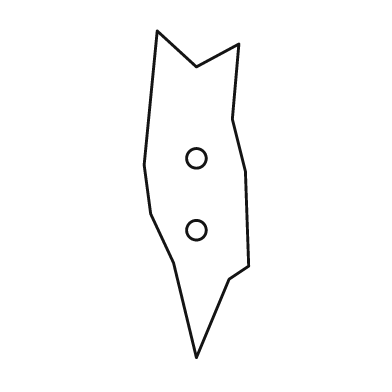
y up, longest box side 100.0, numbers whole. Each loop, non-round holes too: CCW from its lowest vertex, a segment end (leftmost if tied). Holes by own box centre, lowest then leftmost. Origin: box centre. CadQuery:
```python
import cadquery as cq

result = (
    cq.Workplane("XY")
    .moveTo(0.0, -50.0)
    .lineTo(10.0, -26.0)
    .lineTo(16.0, -22.0)
    .lineTo(15.0, 7.0)
    .lineTo(11.0, 23.0)
    .lineTo(13.0, 46.0)
    .lineTo(0.0, 39.0)
    .lineTo(-12.0, 50.0)
    .lineTo(-16.0, 9.0)
    .lineTo(-14.0, -6.0)
    .lineTo(-7.0, -21.0)
    .close()
    .moveTo(0.0, -11.0)
    .circle(3.0)
    .moveTo(0.0, 11.0)
    .circle(3.0)
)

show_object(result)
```